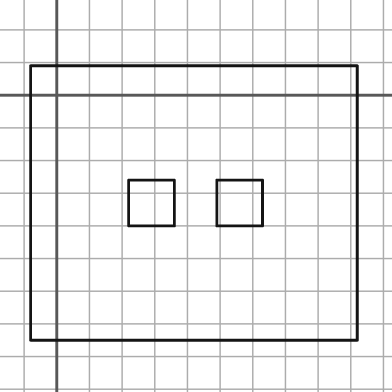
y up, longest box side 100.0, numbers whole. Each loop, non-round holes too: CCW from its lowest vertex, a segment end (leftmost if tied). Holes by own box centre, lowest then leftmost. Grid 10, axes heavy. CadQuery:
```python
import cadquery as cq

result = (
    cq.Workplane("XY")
    .moveTo(-8.0, -75.0)
    .lineTo(92.0, -75.0)
    .lineTo(92.0, 9.0)
    .lineTo(-8.0, 9.0)
    .close()
    .moveTo(22.0, -40.0)
    .lineTo(36.0, -40.0)
    .lineTo(36.0, -26.0)
    .lineTo(22.0, -26.0)
    .close()
    .moveTo(49.0, -40.0)
    .lineTo(63.0, -40.0)
    .lineTo(63.0, -26.0)
    .lineTo(49.0, -26.0)
    .close()
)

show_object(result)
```